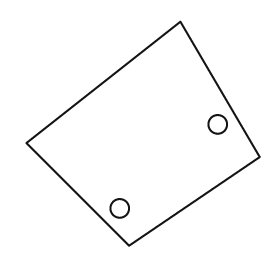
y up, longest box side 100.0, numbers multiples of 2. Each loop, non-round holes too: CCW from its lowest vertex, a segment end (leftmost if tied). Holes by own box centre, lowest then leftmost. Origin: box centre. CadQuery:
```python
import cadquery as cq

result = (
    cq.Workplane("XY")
    .moveTo(-6.0, -48.0)
    .lineTo(50.0, -10.0)
    .lineTo(16.0, 48.0)
    .lineTo(-50.0, -4.0)
    .close()
    .moveTo(-10.0, -32.0)
    .circle(4.0)
    .moveTo(32.0, 4.0)
    .circle(4.0)
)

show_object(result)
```